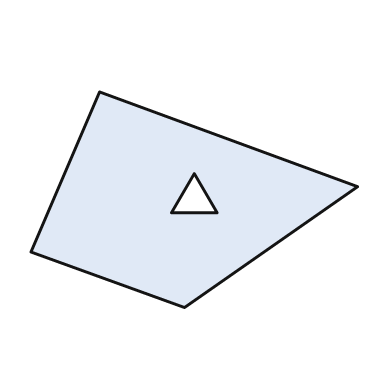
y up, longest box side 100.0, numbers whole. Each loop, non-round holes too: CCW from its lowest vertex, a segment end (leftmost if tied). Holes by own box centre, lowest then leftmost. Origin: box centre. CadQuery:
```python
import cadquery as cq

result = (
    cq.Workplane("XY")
    .moveTo(-3.0, -33.0)
    .lineTo(50.0, 4.0)
    .lineTo(-29.0, 33.0)
    .lineTo(-50.0, -16.0)
    .close()
    .moveTo(-7.0, -4.0)
    .lineTo(7.0, -4.0)
    .lineTo(0.0, 8.0)
    .close()
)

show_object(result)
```